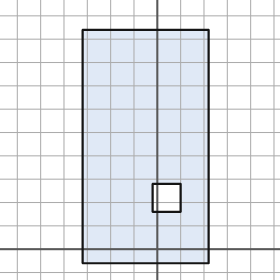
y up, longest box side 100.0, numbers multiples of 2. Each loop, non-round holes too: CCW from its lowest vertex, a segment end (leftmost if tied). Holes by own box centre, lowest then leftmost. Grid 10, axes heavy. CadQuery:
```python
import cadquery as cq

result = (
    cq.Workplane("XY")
    .moveTo(-32.0, -6.0)
    .lineTo(22.0, -6.0)
    .lineTo(22.0, 94.0)
    .lineTo(-32.0, 94.0)
    .close()
    .moveTo(-2.0, 16.0)
    .lineTo(10.0, 16.0)
    .lineTo(10.0, 28.0)
    .lineTo(-2.0, 28.0)
    .close()
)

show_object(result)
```